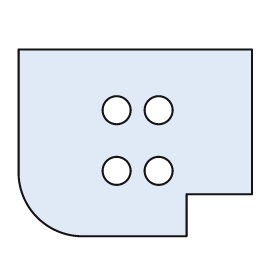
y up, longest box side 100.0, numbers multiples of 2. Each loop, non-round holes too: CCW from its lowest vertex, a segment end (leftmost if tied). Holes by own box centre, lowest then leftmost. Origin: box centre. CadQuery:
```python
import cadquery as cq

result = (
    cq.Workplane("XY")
    .moveTo(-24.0, -40.0)
    .lineTo(22.0, -40.0)
    .lineTo(22.0, -22.0)
    .lineTo(50.0, -22.0)
    .lineTo(50.0, 40.0)
    .lineTo(-50.0, 40.0)
    .lineTo(-50.0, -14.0)
    .threePointArc((-42.0, -32.0), (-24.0, -40.0))
    .close()
    .moveTo(-8.0, -12.0)
    .circle(6.0)
    .moveTo(10.0, -12.0)
    .circle(6.0)
    .moveTo(-8.0, 14.0)
    .circle(6.0)
    .moveTo(10.0, 14.0)
    .circle(6.0)
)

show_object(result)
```